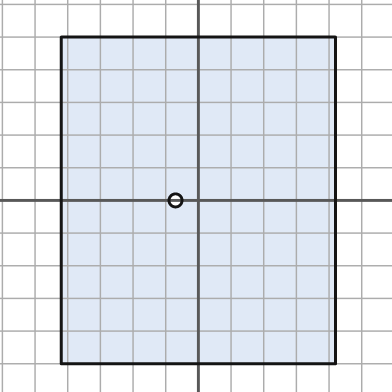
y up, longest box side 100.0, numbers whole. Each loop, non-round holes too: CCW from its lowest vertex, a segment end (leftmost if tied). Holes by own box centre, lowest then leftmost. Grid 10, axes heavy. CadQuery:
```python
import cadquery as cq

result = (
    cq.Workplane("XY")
    .moveTo(-42.0, -50.0)
    .lineTo(42.0, -50.0)
    .lineTo(42.0, 50.0)
    .lineTo(-42.0, 50.0)
    .close()
    .moveTo(-7.0, 0.0)
    .circle(2.0)
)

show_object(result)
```